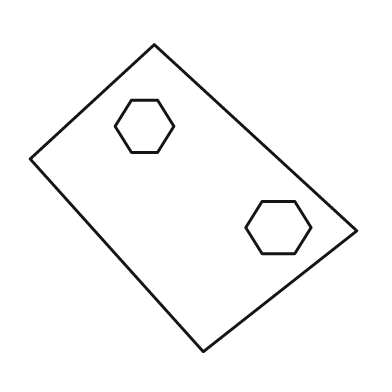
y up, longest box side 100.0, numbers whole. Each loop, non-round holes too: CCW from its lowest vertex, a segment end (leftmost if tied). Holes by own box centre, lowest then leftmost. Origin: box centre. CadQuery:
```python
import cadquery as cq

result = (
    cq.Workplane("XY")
    .moveTo(3.0, -47.0)
    .lineTo(50.0, -10.0)
    .lineTo(-12.0, 47.0)
    .lineTo(-50.0, 12.0)
    .close()
    .moveTo(21.0, -17.0)
    .lineTo(31.0, -17.0)
    .lineTo(36.0, -9.0)
    .lineTo(31.0, -1.0)
    .lineTo(21.0, -1.0)
    .lineTo(16.0, -9.0)
    .close()
    .moveTo(-19.0, 14.0)
    .lineTo(-11.0, 14.0)
    .lineTo(-6.0, 22.0)
    .lineTo(-11.0, 30.0)
    .lineTo(-19.0, 30.0)
    .lineTo(-24.0, 22.0)
    .close()
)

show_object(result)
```